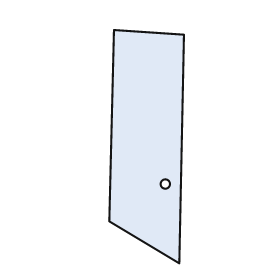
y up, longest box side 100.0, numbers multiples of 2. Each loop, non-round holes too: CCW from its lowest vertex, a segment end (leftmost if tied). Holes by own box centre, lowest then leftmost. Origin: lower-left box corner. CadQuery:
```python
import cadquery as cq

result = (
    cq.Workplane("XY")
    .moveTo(30.0, 0.0)
    .lineTo(32.0, 98.0)
    .lineTo(2.0, 100.0)
    .lineTo(0.0, 18.0)
    .close()
    .moveTo(24.0, 34.0)
    .circle(2.0)
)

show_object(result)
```